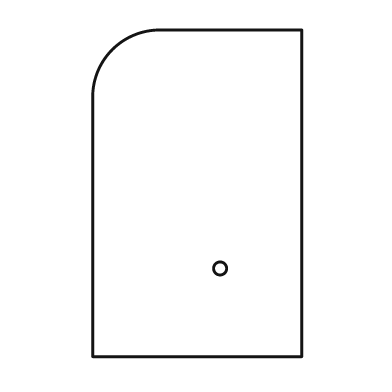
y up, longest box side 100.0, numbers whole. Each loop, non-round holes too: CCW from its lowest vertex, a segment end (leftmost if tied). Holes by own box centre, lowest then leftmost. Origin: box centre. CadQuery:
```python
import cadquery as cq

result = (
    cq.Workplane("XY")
    .moveTo(-32.0, -50.0)
    .lineTo(32.0, -50.0)
    .lineTo(32.0, 50.0)
    .lineTo(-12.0, 50.0)
    .threePointArc((-26.0, 44.0), (-32.0, 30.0))
    .close()
    .moveTo(7.0, -23.0)
    .circle(2.0)
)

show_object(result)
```